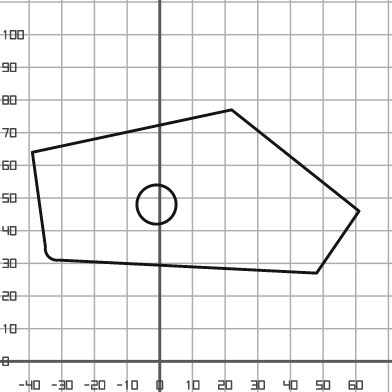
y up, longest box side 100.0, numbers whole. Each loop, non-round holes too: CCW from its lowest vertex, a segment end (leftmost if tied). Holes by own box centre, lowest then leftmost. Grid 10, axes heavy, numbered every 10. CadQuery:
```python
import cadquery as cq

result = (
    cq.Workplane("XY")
    .moveTo(48.0, 27.0)
    .lineTo(61.0, 46.0)
    .lineTo(22.0, 77.0)
    .lineTo(-39.0, 64.0)
    .lineTo(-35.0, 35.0)
    .threePointArc((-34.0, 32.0), (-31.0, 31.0))
    .close()
    .moveTo(-1.0, 48.0)
    .circle(6.0)
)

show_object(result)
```